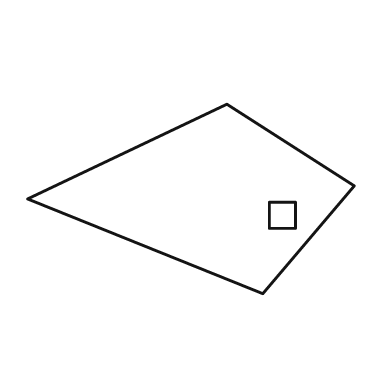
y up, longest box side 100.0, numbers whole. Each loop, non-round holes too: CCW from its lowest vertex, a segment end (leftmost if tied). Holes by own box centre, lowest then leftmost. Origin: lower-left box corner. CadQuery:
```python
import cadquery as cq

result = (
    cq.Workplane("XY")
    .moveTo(72.0, 0.0)
    .lineTo(100.0, 33.0)
    .lineTo(61.0, 58.0)
    .lineTo(0.0, 29.0)
    .close()
    .moveTo(74.0, 20.0)
    .lineTo(82.0, 20.0)
    .lineTo(82.0, 28.0)
    .lineTo(74.0, 28.0)
    .close()
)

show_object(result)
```